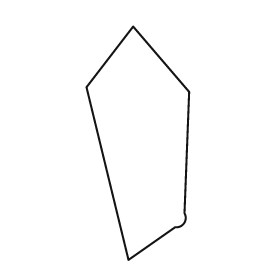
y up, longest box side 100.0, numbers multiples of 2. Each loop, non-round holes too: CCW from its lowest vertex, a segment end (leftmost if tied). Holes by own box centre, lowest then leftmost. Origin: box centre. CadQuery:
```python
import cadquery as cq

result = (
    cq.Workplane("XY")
    .moveTo(-4.0, -50.0)
    .lineTo(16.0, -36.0)
    .threePointArc((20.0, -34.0), (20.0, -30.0))
    .lineTo(22.0, 22.0)
    .lineTo(-2.0, 50.0)
    .lineTo(-22.0, 24.0)
    .close()
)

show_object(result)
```